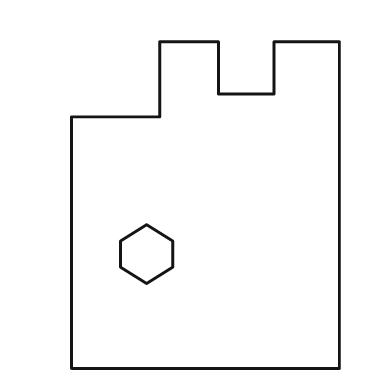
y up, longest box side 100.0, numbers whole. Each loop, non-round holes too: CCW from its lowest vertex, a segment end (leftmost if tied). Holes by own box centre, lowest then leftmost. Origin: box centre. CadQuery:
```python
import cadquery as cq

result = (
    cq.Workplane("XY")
    .moveTo(-41.0, -50.0)
    .lineTo(41.0, -50.0)
    .lineTo(41.0, 50.0)
    .lineTo(21.0, 50.0)
    .lineTo(21.0, 34.0)
    .lineTo(4.0, 34.0)
    .lineTo(4.0, 50.0)
    .lineTo(-14.0, 50.0)
    .lineTo(-14.0, 27.0)
    .lineTo(-41.0, 27.0)
    .close()
    .moveTo(-18.0, -24.0)
    .lineTo(-10.0, -19.0)
    .lineTo(-10.0, -11.0)
    .lineTo(-18.0, -6.0)
    .lineTo(-26.0, -11.0)
    .lineTo(-26.0, -19.0)
    .close()
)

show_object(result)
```